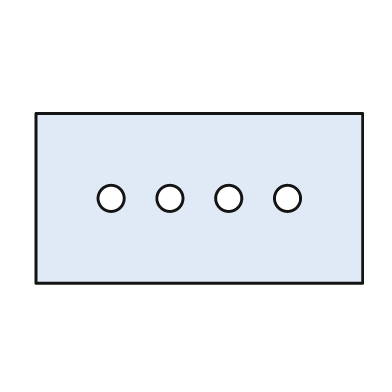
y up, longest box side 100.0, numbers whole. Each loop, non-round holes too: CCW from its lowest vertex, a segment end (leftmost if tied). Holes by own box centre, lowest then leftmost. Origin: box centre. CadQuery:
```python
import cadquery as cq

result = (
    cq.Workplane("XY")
    .moveTo(-50.0, -26.0)
    .lineTo(50.0, -26.0)
    .lineTo(50.0, 26.0)
    .lineTo(-50.0, 26.0)
    .close()
    .moveTo(-27.0, 0.0)
    .circle(4.0)
    .moveTo(-9.0, 0.0)
    .circle(4.0)
    .moveTo(9.0, 0.0)
    .circle(4.0)
    .moveTo(27.0, 0.0)
    .circle(4.0)
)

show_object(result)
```